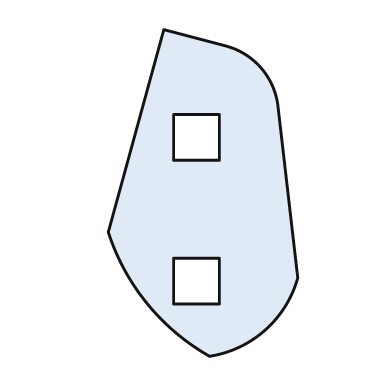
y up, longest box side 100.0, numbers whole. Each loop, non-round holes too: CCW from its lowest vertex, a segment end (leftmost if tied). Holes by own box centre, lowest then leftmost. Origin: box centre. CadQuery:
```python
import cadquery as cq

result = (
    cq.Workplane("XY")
    .moveTo(2.0, -50.0)
    .threePointArc((19.0, -42.0), (29.0, -26.0))
    .lineTo(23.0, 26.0)
    .threePointArc((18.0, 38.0), (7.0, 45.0))
    .lineTo(-12.0, 50.0)
    .lineTo(-29.0, -12.0)
    .threePointArc((-17.0, -34.0), (2.0, -50.0))
    .close()
    .moveTo(-9.0, -34.0)
    .lineTo(5.0, -34.0)
    .lineTo(5.0, -20.0)
    .lineTo(-9.0, -20.0)
    .close()
    .moveTo(-9.0, 10.0)
    .lineTo(5.0, 10.0)
    .lineTo(5.0, 24.0)
    .lineTo(-9.0, 24.0)
    .close()
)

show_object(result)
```